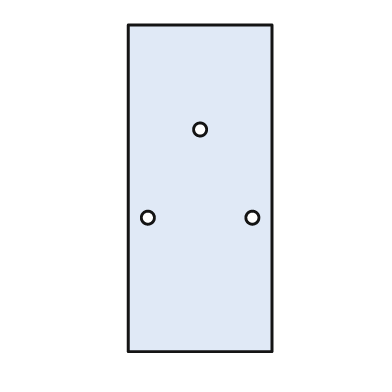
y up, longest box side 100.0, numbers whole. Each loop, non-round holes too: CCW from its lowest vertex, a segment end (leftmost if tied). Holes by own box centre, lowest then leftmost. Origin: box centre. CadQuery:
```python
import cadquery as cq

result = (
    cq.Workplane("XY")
    .moveTo(-22.0, -50.0)
    .lineTo(22.0, -50.0)
    .lineTo(22.0, 50.0)
    .lineTo(-22.0, 50.0)
    .close()
    .moveTo(-16.0, -9.0)
    .circle(2.0)
    .moveTo(16.0, -9.0)
    .circle(2.0)
    .moveTo(0.0, 18.0)
    .circle(2.0)
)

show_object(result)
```